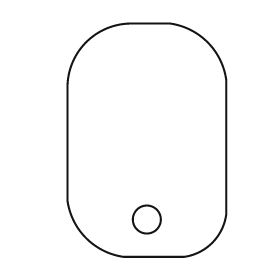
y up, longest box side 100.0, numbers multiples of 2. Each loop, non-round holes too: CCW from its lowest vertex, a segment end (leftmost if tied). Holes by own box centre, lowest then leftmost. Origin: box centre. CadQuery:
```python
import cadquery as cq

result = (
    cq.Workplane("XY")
    .moveTo(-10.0, -50.0)
    .lineTo(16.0, -50.0)
    .threePointArc((28.0, -44.0), (34.0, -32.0))
    .lineTo(34.0, 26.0)
    .threePointArc((26.0, 42.0), (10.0, 50.0))
    .lineTo(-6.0, 50.0)
    .threePointArc((-26.0, 42.0), (-34.0, 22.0))
    .lineTo(-34.0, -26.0)
    .threePointArc((-26.0, -42.0), (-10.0, -50.0))
    .close()
    .moveTo(0.0, -34.0)
    .circle(6.0)
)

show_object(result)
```